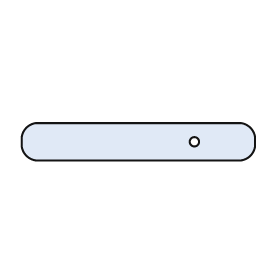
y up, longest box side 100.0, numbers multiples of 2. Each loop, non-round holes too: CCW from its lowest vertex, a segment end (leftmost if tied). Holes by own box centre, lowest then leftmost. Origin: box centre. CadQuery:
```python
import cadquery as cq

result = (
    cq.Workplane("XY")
    .moveTo(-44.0, -8.0)
    .lineTo(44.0, -8.0)
    .threePointArc((48.0, -6.0), (50.0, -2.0))
    .lineTo(50.0, 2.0)
    .threePointArc((48.0, 6.0), (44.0, 8.0))
    .lineTo(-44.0, 8.0)
    .threePointArc((-48.0, 6.0), (-50.0, 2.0))
    .lineTo(-50.0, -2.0)
    .threePointArc((-48.0, -6.0), (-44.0, -8.0))
    .close()
    .moveTo(24.0, 0.0)
    .circle(2.0)
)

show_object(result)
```